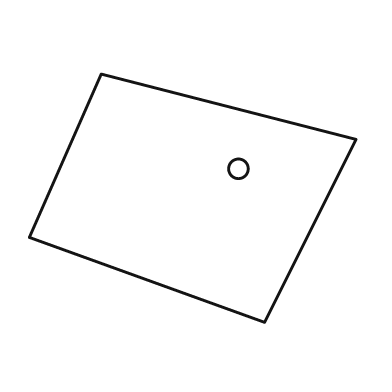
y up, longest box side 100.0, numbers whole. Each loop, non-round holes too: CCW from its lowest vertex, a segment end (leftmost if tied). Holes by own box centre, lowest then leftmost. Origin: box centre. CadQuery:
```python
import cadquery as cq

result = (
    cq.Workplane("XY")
    .moveTo(22.0, -38.0)
    .lineTo(50.0, 18.0)
    .lineTo(-28.0, 38.0)
    .lineTo(-50.0, -12.0)
    .close()
    .moveTo(14.0, 9.0)
    .circle(3.0)
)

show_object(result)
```